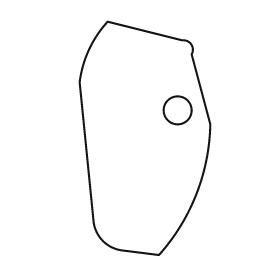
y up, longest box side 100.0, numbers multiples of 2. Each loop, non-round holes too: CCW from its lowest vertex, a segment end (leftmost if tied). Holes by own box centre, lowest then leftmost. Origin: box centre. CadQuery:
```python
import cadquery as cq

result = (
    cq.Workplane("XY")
    .moveTo(6.0, -50.0)
    .threePointArc((22.0, -24.0), (28.0, 6.0))
    .lineTo(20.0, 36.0)
    .threePointArc((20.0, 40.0), (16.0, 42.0))
    .lineTo(-16.0, 50.0)
    .threePointArc((-24.0, 38.0), (-28.0, 24.0))
    .lineTo(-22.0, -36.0)
    .threePointArc((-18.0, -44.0), (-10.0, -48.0))
    .close()
    .moveTo(14.0, 12.0)
    .circle(6.0)
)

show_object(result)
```